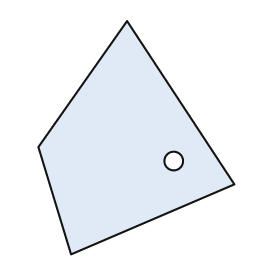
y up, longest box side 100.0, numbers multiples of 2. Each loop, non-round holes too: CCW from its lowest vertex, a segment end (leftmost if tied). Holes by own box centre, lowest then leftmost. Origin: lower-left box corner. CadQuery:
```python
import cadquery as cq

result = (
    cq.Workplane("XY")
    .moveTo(14.0, 0.0)
    .lineTo(84.0, 30.0)
    .lineTo(38.0, 100.0)
    .lineTo(0.0, 46.0)
    .close()
    .moveTo(58.0, 40.0)
    .circle(4.0)
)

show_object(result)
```